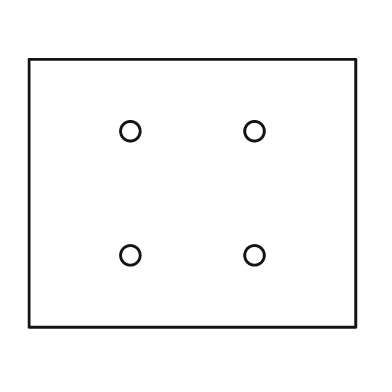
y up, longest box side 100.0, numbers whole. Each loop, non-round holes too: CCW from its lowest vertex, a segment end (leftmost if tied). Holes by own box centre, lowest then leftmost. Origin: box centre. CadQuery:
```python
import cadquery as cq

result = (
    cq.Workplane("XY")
    .moveTo(-50.0, -41.0)
    .lineTo(50.0, -41.0)
    .lineTo(50.0, 41.0)
    .lineTo(-50.0, 41.0)
    .close()
    .moveTo(-19.0, -19.0)
    .circle(3.0)
    .moveTo(19.0, -19.0)
    .circle(3.0)
    .moveTo(-19.0, 19.0)
    .circle(3.0)
    .moveTo(19.0, 19.0)
    .circle(3.0)
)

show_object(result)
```